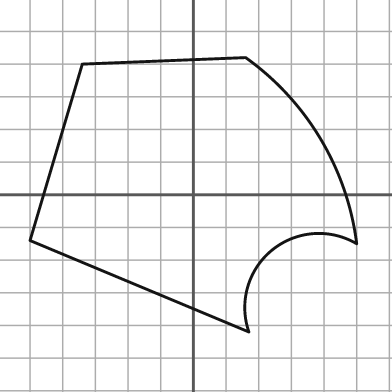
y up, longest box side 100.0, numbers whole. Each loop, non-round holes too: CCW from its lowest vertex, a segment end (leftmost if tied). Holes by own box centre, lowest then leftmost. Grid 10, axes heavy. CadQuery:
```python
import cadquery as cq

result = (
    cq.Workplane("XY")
    .moveTo(17.0, -42.0)
    .threePointArc((24.0, -17.0), (50.0, -15.0))
    .threePointArc((39.0, 17.0), (16.0, 42.0))
    .lineTo(-34.0, 40.0)
    .lineTo(-50.0, -14.0)
    .close()
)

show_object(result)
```